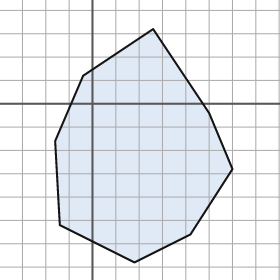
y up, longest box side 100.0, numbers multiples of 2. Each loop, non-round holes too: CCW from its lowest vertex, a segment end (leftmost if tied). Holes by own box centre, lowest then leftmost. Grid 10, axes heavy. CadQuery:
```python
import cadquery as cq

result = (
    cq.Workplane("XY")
    .moveTo(18.0, -68.0)
    .lineTo(42.0, -56.0)
    .lineTo(60.0, -28.0)
    .lineTo(50.0, -4.0)
    .lineTo(26.0, 32.0)
    .lineTo(-4.0, 12.0)
    .lineTo(-16.0, -16.0)
    .lineTo(-14.0, -52.0)
    .close()
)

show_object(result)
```